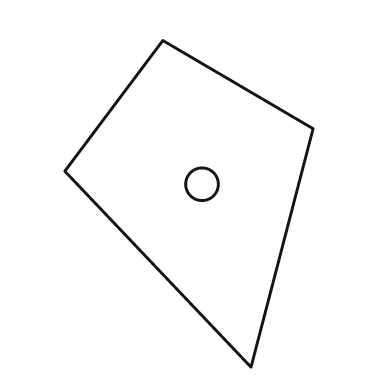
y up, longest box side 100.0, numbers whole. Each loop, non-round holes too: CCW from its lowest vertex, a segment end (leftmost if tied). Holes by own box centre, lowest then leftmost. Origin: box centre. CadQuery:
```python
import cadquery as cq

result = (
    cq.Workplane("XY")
    .moveTo(19.0, -50.0)
    .lineTo(38.0, 23.0)
    .lineTo(-8.0, 50.0)
    .lineTo(-38.0, 10.0)
    .close()
    .moveTo(4.0, 6.0)
    .circle(5.0)
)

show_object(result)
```